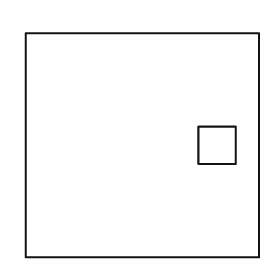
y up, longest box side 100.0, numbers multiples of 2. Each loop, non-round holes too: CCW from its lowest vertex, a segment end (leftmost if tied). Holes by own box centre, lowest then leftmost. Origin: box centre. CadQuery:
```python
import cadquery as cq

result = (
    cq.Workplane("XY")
    .moveTo(-50.0, -48.0)
    .lineTo(50.0, -48.0)
    .lineTo(50.0, 48.0)
    .lineTo(-50.0, 48.0)
    .close()
    .moveTo(24.0, -8.0)
    .lineTo(40.0, -8.0)
    .lineTo(40.0, 8.0)
    .lineTo(24.0, 8.0)
    .close()
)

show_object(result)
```